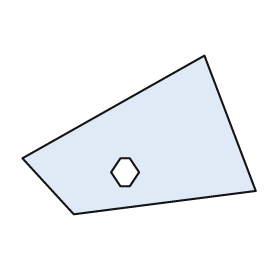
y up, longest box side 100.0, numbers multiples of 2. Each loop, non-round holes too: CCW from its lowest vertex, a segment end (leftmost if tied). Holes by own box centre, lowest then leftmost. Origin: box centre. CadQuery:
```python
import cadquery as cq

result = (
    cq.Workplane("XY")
    .moveTo(-28.0, -34.0)
    .lineTo(50.0, -24.0)
    .lineTo(28.0, 34.0)
    .lineTo(-50.0, -10.0)
    .close()
    .moveTo(-8.0, -22.0)
    .lineTo(-4.0, -22.0)
    .lineTo(0.0, -16.0)
    .lineTo(-4.0, -10.0)
    .lineTo(-8.0, -10.0)
    .lineTo(-12.0, -16.0)
    .close()
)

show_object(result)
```